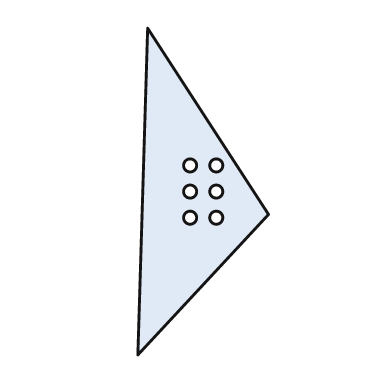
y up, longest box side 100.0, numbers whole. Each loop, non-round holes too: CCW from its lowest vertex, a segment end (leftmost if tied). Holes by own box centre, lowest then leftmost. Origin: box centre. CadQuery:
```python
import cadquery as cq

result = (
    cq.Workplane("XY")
    .moveTo(-20.0, -50.0)
    .lineTo(20.0, -7.0)
    .lineTo(-17.0, 50.0)
    .close()
    .moveTo(-4.0, -8.0)
    .circle(2.0)
    .moveTo(4.0, -8.0)
    .circle(2.0)
    .moveTo(-4.0, 0.0)
    .circle(2.0)
    .moveTo(4.0, 0.0)
    .circle(2.0)
    .moveTo(-4.0, 8.0)
    .circle(2.0)
    .moveTo(4.0, 8.0)
    .circle(2.0)
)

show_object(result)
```